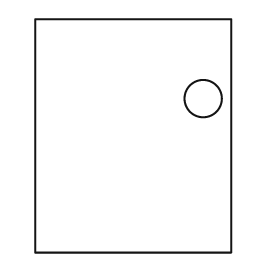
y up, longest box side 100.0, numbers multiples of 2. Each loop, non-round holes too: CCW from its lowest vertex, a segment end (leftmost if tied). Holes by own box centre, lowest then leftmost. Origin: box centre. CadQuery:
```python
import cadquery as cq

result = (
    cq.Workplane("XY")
    .moveTo(-42.0, -50.0)
    .lineTo(42.0, -50.0)
    .lineTo(42.0, 50.0)
    .lineTo(-42.0, 50.0)
    .close()
    .moveTo(30.0, 16.0)
    .circle(8.0)
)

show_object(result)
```